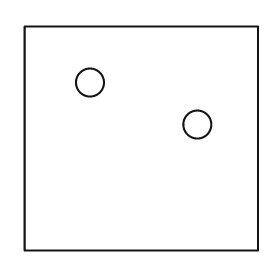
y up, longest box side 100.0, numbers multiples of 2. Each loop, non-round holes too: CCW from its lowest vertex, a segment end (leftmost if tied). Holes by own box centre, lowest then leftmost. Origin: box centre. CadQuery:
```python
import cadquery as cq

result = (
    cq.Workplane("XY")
    .moveTo(-50.0, -48.0)
    .lineTo(50.0, -48.0)
    .lineTo(50.0, 48.0)
    .lineTo(-50.0, 48.0)
    .close()
    .moveTo(24.0, 6.0)
    .circle(6.0)
    .moveTo(-22.0, 24.0)
    .circle(6.0)
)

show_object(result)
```